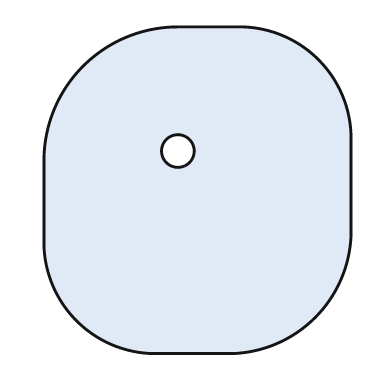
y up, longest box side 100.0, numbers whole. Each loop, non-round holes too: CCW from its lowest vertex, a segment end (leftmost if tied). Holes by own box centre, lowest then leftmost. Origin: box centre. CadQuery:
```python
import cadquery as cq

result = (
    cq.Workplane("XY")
    .moveTo(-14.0, -50.0)
    .lineTo(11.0, -50.0)
    .threePointArc((36.0, -39.0), (47.0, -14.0))
    .lineTo(47.0, 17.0)
    .threePointArc((37.0, 40.0), (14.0, 50.0))
    .lineTo(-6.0, 50.0)
    .threePointArc((-35.0, 38.0), (-47.0, 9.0))
    .lineTo(-47.0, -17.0)
    .threePointArc((-37.0, -40.0), (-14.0, -50.0))
    .close()
    .moveTo(-6.0, 12.0)
    .circle(5.0)
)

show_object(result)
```